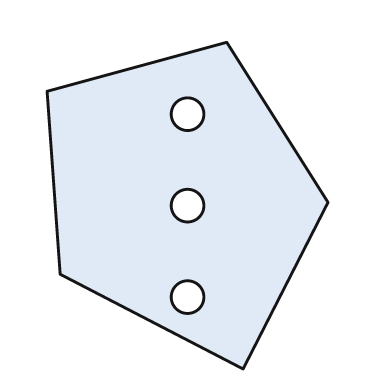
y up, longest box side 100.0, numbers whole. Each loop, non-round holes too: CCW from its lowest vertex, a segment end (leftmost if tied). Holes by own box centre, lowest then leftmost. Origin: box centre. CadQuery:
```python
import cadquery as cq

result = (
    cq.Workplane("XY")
    .moveTo(17.0, -50.0)
    .lineTo(43.0, 1.0)
    .lineTo(12.0, 50.0)
    .lineTo(-43.0, 35.0)
    .lineTo(-39.0, -21.0)
    .close()
    .moveTo(0.0, -28.0)
    .circle(5.0)
    .moveTo(0.0, 0.0)
    .circle(5.0)
    .moveTo(0.0, 28.0)
    .circle(5.0)
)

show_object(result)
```